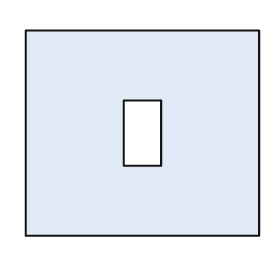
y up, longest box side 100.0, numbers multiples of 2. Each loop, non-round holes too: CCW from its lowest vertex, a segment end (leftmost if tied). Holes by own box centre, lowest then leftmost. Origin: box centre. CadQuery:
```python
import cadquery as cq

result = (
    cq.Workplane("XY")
    .moveTo(-50.0, -44.0)
    .lineTo(50.0, -44.0)
    .lineTo(50.0, 44.0)
    .lineTo(-50.0, 44.0)
    .close()
    .moveTo(-8.0, -14.0)
    .lineTo(8.0, -14.0)
    .lineTo(8.0, 14.0)
    .lineTo(-8.0, 14.0)
    .close()
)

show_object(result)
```